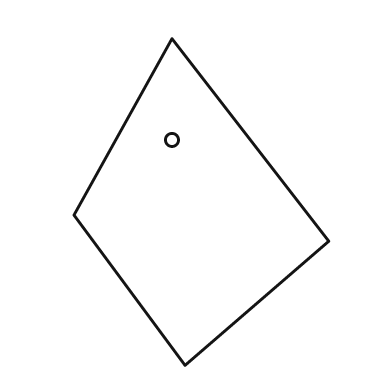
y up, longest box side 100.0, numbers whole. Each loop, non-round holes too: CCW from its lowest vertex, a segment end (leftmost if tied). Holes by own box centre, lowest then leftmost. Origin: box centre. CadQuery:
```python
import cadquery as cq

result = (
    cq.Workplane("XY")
    .moveTo(-5.0, -50.0)
    .lineTo(39.0, -12.0)
    .lineTo(-9.0, 50.0)
    .lineTo(-39.0, -4.0)
    .close()
    .moveTo(-9.0, 19.0)
    .circle(2.0)
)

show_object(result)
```